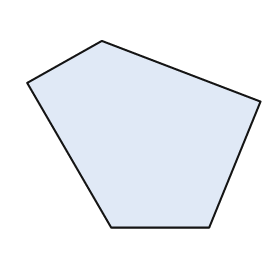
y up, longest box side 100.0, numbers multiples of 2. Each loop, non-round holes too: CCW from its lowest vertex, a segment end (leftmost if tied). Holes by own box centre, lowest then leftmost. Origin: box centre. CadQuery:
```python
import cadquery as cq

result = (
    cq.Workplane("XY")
    .moveTo(-14.0, -40.0)
    .lineTo(28.0, -40.0)
    .lineTo(50.0, 14.0)
    .lineTo(-18.0, 40.0)
    .lineTo(-50.0, 22.0)
    .close()
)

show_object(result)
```